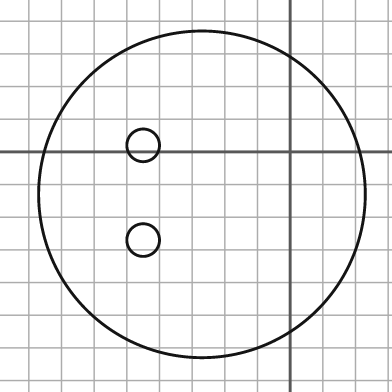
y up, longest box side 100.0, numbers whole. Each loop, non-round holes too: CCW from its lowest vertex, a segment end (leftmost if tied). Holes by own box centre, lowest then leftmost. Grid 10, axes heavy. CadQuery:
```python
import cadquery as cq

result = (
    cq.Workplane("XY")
    .moveTo(-27.0, -13.0)
    .circle(50.0)
    .moveTo(-45.0, -27.0)
    .circle(5.0)
    .moveTo(-45.0, 2.0)
    .circle(5.0)
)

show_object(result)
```